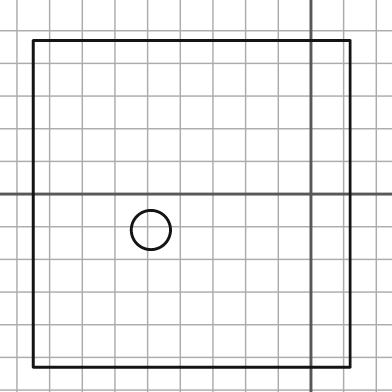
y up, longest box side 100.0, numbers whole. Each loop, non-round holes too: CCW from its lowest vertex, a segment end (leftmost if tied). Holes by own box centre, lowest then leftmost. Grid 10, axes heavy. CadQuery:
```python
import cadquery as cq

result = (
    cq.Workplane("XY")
    .moveTo(-85.0, -53.0)
    .lineTo(12.0, -53.0)
    .lineTo(12.0, 47.0)
    .lineTo(-85.0, 47.0)
    .close()
    .moveTo(-49.0, -11.0)
    .circle(6.0)
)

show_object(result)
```